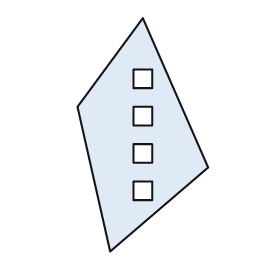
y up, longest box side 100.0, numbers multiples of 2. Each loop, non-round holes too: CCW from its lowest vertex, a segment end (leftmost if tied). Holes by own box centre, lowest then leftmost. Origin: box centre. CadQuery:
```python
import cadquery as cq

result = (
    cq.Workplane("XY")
    .moveTo(-14.0, -50.0)
    .lineTo(28.0, -14.0)
    .lineTo(0.0, 50.0)
    .lineTo(-28.0, 12.0)
    .close()
    .moveTo(-4.0, -28.0)
    .lineTo(4.0, -28.0)
    .lineTo(4.0, -20.0)
    .lineTo(-4.0, -20.0)
    .close()
    .moveTo(-4.0, -12.0)
    .lineTo(4.0, -12.0)
    .lineTo(4.0, -4.0)
    .lineTo(-4.0, -4.0)
    .close()
    .moveTo(-4.0, 4.0)
    .lineTo(4.0, 4.0)
    .lineTo(4.0, 12.0)
    .lineTo(-4.0, 12.0)
    .close()
    .moveTo(-4.0, 20.0)
    .lineTo(4.0, 20.0)
    .lineTo(4.0, 28.0)
    .lineTo(-4.0, 28.0)
    .close()
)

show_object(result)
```